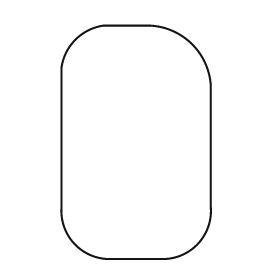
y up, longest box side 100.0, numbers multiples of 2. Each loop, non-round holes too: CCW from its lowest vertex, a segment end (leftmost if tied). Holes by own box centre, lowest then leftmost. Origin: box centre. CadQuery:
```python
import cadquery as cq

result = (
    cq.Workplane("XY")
    .moveTo(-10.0, -50.0)
    .lineTo(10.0, -50.0)
    .threePointArc((26.0, -44.0), (32.0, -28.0))
    .lineTo(32.0, 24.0)
    .threePointArc((24.0, 42.0), (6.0, 50.0))
    .lineTo(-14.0, 50.0)
    .threePointArc((-26.0, 44.0), (-32.0, 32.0))
    .lineTo(-32.0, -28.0)
    .threePointArc((-26.0, -44.0), (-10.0, -50.0))
    .close()
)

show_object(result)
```